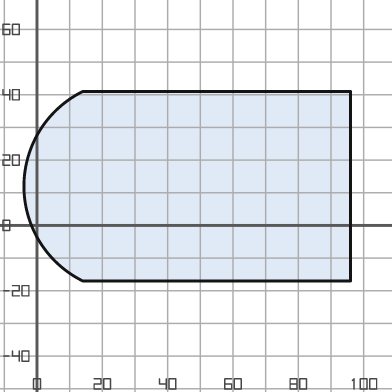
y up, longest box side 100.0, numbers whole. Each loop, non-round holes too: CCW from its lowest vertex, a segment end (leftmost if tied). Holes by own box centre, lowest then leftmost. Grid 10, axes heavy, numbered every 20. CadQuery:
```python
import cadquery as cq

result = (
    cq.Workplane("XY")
    .moveTo(14.0, -17.0)
    .lineTo(96.0, -17.0)
    .lineTo(96.0, 41.0)
    .lineTo(14.0, 41.0)
    .threePointArc((-4.0, 12.0), (14.0, -17.0))
    .close()
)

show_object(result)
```